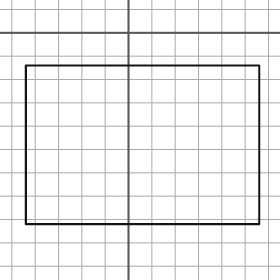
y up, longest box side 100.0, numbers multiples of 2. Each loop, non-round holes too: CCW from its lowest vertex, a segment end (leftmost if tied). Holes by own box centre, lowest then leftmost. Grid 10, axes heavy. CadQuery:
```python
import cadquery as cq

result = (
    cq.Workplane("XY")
    .moveTo(-44.0, -82.0)
    .lineTo(56.0, -82.0)
    .lineTo(56.0, -14.0)
    .lineTo(-44.0, -14.0)
    .close()
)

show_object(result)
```